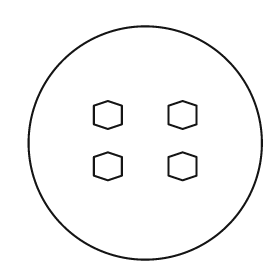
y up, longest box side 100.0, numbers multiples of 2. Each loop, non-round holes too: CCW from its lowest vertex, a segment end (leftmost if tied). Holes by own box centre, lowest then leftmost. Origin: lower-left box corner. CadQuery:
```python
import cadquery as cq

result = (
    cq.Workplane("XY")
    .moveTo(50.0, 50.0)
    .circle(50.0)
    .moveTo(34.0, 34.0)
    .lineTo(40.0, 36.0)
    .lineTo(40.0, 44.0)
    .lineTo(34.0, 46.0)
    .lineTo(28.0, 44.0)
    .lineTo(28.0, 36.0)
    .close()
    .moveTo(66.0, 34.0)
    .lineTo(72.0, 36.0)
    .lineTo(72.0, 44.0)
    .lineTo(66.0, 46.0)
    .lineTo(60.0, 44.0)
    .lineTo(60.0, 36.0)
    .close()
    .moveTo(34.0, 56.0)
    .lineTo(40.0, 58.0)
    .lineTo(40.0, 66.0)
    .lineTo(34.0, 68.0)
    .lineTo(28.0, 66.0)
    .lineTo(28.0, 58.0)
    .close()
    .moveTo(66.0, 56.0)
    .lineTo(72.0, 58.0)
    .lineTo(72.0, 66.0)
    .lineTo(66.0, 68.0)
    .lineTo(60.0, 66.0)
    .lineTo(60.0, 58.0)
    .close()
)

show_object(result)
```